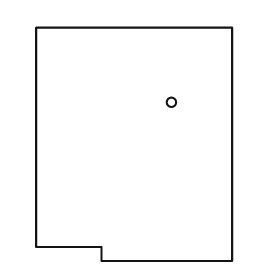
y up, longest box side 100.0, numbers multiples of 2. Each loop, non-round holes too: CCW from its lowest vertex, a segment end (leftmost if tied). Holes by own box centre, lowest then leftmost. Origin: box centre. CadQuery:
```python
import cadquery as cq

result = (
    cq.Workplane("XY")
    .moveTo(-14.0, -50.0)
    .lineTo(42.0, -50.0)
    .lineTo(42.0, 50.0)
    .lineTo(-42.0, 50.0)
    .lineTo(-42.0, -44.0)
    .lineTo(-14.0, -44.0)
    .close()
    .moveTo(16.0, 18.0)
    .circle(2.0)
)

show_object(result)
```